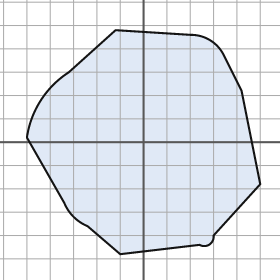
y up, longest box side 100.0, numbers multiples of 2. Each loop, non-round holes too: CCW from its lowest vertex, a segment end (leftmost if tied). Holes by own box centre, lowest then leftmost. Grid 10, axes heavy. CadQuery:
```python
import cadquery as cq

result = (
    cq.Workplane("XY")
    .moveTo(-10.0, -48.0)
    .lineTo(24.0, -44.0)
    .threePointArc((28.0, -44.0), (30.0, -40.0))
    .lineTo(50.0, -18.0)
    .lineTo(42.0, 22.0)
    .lineTo(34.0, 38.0)
    .threePointArc((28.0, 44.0), (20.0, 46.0))
    .lineTo(-12.0, 48.0)
    .lineTo(-32.0, 30.0)
    .threePointArc((-44.0, 18.0), (-50.0, 2.0))
    .lineTo(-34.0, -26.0)
    .threePointArc((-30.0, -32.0), (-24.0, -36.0))
    .close()
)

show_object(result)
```